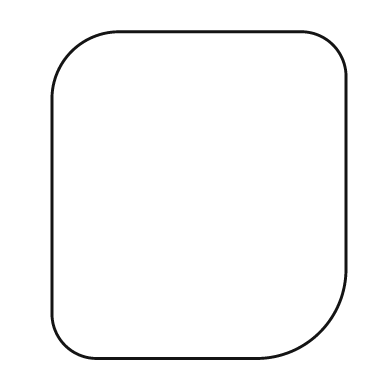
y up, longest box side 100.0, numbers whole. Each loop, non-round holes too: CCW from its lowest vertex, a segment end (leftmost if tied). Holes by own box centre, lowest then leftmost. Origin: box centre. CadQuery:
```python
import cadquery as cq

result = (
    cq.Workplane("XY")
    .moveTo(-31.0, -50.0)
    .lineTo(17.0, -50.0)
    .threePointArc((37.0, -42.0), (45.0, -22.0))
    .lineTo(45.0, 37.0)
    .threePointArc((41.0, 46.0), (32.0, 50.0))
    .lineTo(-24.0, 50.0)
    .threePointArc((-39.0, 44.0), (-45.0, 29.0))
    .lineTo(-45.0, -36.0)
    .threePointArc((-41.0, -46.0), (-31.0, -50.0))
    .close()
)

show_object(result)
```